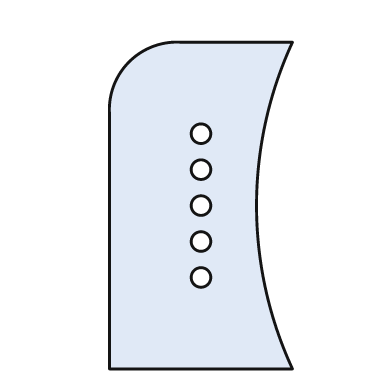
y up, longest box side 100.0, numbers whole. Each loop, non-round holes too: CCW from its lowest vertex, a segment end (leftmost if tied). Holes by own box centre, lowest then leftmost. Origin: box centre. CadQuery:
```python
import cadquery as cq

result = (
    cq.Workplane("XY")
    .moveTo(-28.0, -50.0)
    .lineTo(28.0, -50.0)
    .threePointArc((17.0, 0.0), (28.0, 50.0))
    .lineTo(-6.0, 50.0)
    .threePointArc((-22.0, 44.0), (-28.0, 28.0))
    .close()
    .moveTo(0.0, -22.0)
    .circle(3.0)
    .moveTo(0.0, -11.0)
    .circle(3.0)
    .moveTo(0.0, 0.0)
    .circle(3.0)
    .moveTo(0.0, 11.0)
    .circle(3.0)
    .moveTo(0.0, 22.0)
    .circle(3.0)
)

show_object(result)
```